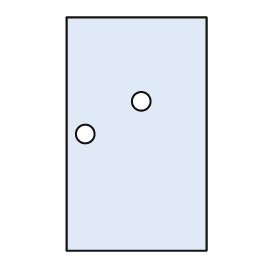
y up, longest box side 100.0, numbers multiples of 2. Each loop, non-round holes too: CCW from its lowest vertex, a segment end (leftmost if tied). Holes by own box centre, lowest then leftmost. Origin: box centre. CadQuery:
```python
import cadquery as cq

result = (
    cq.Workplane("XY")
    .moveTo(-30.0, -50.0)
    .lineTo(30.0, -50.0)
    .lineTo(30.0, 50.0)
    .lineTo(-30.0, 50.0)
    .close()
    .moveTo(-22.0, 0.0)
    .circle(4.0)
    .moveTo(2.0, 14.0)
    .circle(4.0)
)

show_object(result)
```